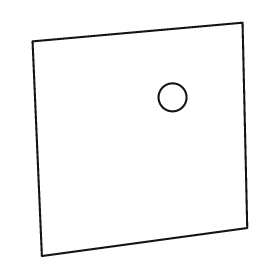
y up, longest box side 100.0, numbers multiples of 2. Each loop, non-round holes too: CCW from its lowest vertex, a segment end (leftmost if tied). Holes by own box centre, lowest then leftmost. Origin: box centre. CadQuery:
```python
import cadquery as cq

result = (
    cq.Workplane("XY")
    .moveTo(-42.0, -50.0)
    .lineTo(46.0, -38.0)
    .lineTo(44.0, 50.0)
    .lineTo(-46.0, 42.0)
    .close()
    .moveTo(14.0, 18.0)
    .circle(6.0)
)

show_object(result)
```